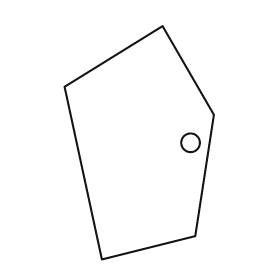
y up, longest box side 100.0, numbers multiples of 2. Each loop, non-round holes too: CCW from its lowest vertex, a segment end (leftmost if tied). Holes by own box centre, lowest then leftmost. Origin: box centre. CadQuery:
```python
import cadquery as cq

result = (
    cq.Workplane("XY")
    .moveTo(-16.0, -50.0)
    .lineTo(24.0, -40.0)
    .lineTo(32.0, 12.0)
    .lineTo(10.0, 50.0)
    .lineTo(-32.0, 24.0)
    .close()
    .moveTo(22.0, 0.0)
    .circle(4.0)
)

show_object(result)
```